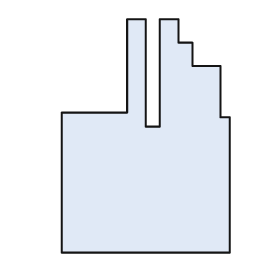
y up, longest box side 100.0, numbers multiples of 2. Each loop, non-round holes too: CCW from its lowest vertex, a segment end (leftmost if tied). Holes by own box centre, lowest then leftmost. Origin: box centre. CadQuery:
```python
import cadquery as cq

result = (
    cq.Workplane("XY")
    .moveTo(-36.0, -50.0)
    .lineTo(36.0, -50.0)
    .lineTo(36.0, 8.0)
    .lineTo(32.0, 8.0)
    .lineTo(32.0, 30.0)
    .lineTo(20.0, 30.0)
    .lineTo(20.0, 40.0)
    .lineTo(14.0, 40.0)
    .lineTo(14.0, 50.0)
    .lineTo(6.0, 50.0)
    .lineTo(6.0, 4.0)
    .lineTo(0.0, 4.0)
    .lineTo(0.0, 50.0)
    .lineTo(-8.0, 50.0)
    .lineTo(-8.0, 10.0)
    .lineTo(-36.0, 10.0)
    .close()
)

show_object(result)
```